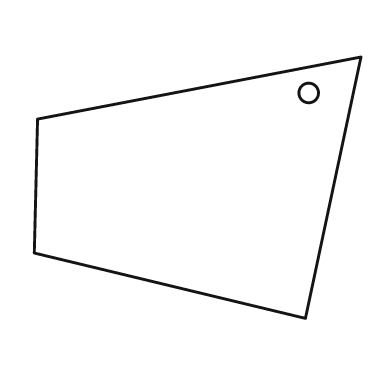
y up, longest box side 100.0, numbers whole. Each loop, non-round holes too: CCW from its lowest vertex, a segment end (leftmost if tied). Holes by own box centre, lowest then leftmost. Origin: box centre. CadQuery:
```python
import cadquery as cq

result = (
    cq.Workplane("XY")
    .moveTo(33.0, -40.0)
    .lineTo(50.0, 40.0)
    .lineTo(-49.0, 21.0)
    .lineTo(-50.0, -20.0)
    .close()
    .moveTo(34.0, 29.0)
    .circle(3.0)
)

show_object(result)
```